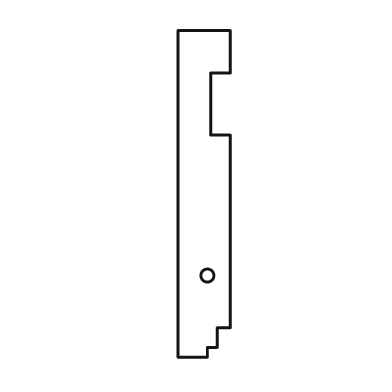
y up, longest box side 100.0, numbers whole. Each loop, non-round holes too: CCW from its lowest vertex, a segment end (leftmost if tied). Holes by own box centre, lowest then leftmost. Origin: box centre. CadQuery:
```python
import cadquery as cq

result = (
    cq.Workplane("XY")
    .moveTo(-8.0, -50.0)
    .lineTo(1.0, -50.0)
    .lineTo(1.0, -47.0)
    .lineTo(4.0, -47.0)
    .lineTo(4.0, -41.0)
    .lineTo(8.0, -41.0)
    .lineTo(8.0, 18.0)
    .lineTo(2.0, 18.0)
    .lineTo(2.0, 37.0)
    .lineTo(8.0, 37.0)
    .lineTo(8.0, 50.0)
    .lineTo(-8.0, 50.0)
    .close()
    .moveTo(1.0, -25.0)
    .circle(2.0)
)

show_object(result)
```